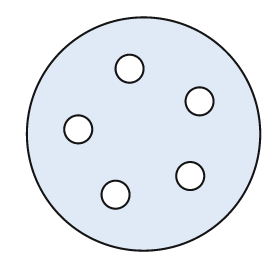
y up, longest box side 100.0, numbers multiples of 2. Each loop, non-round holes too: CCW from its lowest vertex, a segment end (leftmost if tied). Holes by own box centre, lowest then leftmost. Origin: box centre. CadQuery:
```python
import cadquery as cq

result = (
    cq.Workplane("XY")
    .moveTo(0.0, 0.0)
    .circle(50.0)
    .moveTo(-12.0, -26.0)
    .circle(6.0)
    .moveTo(20.0, -18.0)
    .circle(6.0)
    .moveTo(-28.0, 2.0)
    .circle(6.0)
    .moveTo(24.0, 14.0)
    .circle(6.0)
    .moveTo(-6.0, 28.0)
    .circle(6.0)
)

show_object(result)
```